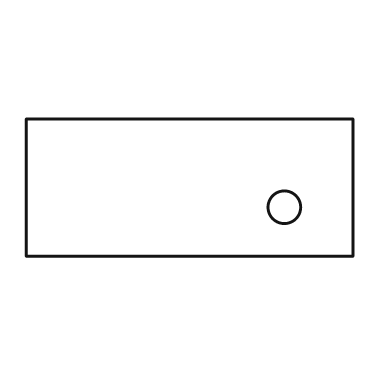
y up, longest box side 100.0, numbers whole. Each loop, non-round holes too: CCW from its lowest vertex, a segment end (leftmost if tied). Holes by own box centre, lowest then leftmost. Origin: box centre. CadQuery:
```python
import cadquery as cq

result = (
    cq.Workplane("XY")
    .moveTo(-50.0, -21.0)
    .lineTo(50.0, -21.0)
    .lineTo(50.0, 21.0)
    .lineTo(-50.0, 21.0)
    .close()
    .moveTo(29.0, -6.0)
    .circle(5.0)
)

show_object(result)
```